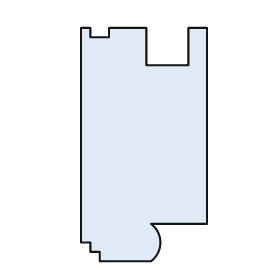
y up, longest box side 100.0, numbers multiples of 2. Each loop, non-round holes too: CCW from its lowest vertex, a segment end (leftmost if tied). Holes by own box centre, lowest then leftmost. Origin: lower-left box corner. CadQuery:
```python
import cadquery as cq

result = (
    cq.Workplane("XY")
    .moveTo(8.0, 0.0)
    .lineTo(30.0, 0.0)
    .threePointArc((34.0, 8.0), (30.0, 16.0))
    .lineTo(54.0, 16.0)
    .lineTo(54.0, 100.0)
    .lineTo(46.0, 100.0)
    .lineTo(46.0, 84.0)
    .lineTo(28.0, 84.0)
    .lineTo(28.0, 100.0)
    .lineTo(12.0, 100.0)
    .lineTo(12.0, 96.0)
    .lineTo(4.0, 96.0)
    .lineTo(4.0, 100.0)
    .lineTo(0.0, 100.0)
    .lineTo(0.0, 8.0)
    .lineTo(4.0, 8.0)
    .lineTo(4.0, 4.0)
    .lineTo(8.0, 4.0)
    .close()
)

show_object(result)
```